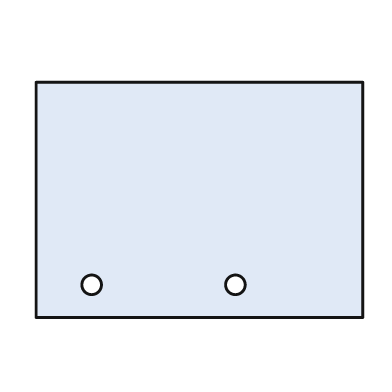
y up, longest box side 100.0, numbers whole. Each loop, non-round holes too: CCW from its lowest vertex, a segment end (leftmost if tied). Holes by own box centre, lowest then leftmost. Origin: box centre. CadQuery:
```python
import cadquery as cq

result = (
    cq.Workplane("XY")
    .moveTo(-50.0, -36.0)
    .lineTo(50.0, -36.0)
    .lineTo(50.0, 36.0)
    .lineTo(-50.0, 36.0)
    .close()
    .moveTo(-33.0, -26.0)
    .circle(3.0)
    .moveTo(11.0, -26.0)
    .circle(3.0)
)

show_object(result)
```